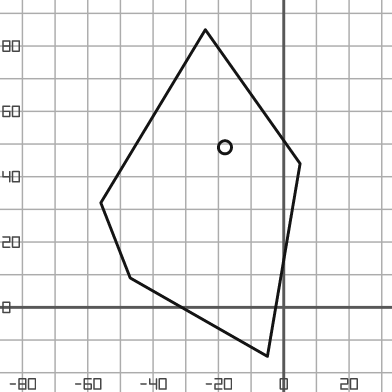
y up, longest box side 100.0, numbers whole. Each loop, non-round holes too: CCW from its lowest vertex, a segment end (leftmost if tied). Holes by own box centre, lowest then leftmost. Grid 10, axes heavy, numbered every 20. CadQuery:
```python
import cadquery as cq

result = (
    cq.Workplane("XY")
    .moveTo(-5.0, -15.0)
    .lineTo(5.0, 44.0)
    .lineTo(-24.0, 85.0)
    .lineTo(-56.0, 32.0)
    .lineTo(-47.0, 9.0)
    .close()
    .moveTo(-18.0, 49.0)
    .circle(2.0)
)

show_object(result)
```